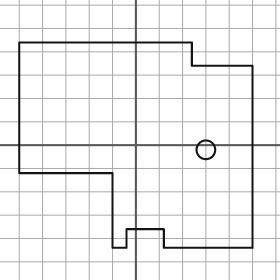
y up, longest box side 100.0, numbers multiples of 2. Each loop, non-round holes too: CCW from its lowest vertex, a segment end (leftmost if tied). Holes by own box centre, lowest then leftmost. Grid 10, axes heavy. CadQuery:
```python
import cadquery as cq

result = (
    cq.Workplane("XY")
    .moveTo(-10.0, -44.0)
    .lineTo(-4.0, -44.0)
    .lineTo(-4.0, -36.0)
    .lineTo(12.0, -36.0)
    .lineTo(12.0, -44.0)
    .lineTo(50.0, -44.0)
    .lineTo(50.0, 34.0)
    .lineTo(24.0, 34.0)
    .lineTo(24.0, 44.0)
    .lineTo(-50.0, 44.0)
    .lineTo(-50.0, -12.0)
    .lineTo(-10.0, -12.0)
    .close()
    .moveTo(30.0, -2.0)
    .circle(4.0)
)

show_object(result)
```